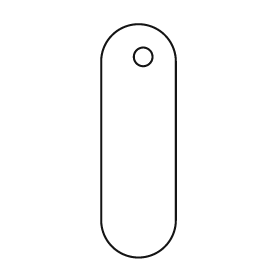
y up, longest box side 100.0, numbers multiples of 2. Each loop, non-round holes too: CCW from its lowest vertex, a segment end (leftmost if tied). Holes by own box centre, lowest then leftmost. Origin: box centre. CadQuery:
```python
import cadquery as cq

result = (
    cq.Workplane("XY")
    .moveTo(-16.0, -34.0)
    .threePointArc((0.0, -50.0), (16.0, -34.0))
    .lineTo(16.0, 34.0)
    .threePointArc((0.0, 50.0), (-16.0, 34.0))
    .close()
    .moveTo(2.0, 36.0)
    .circle(4.0)
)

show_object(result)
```